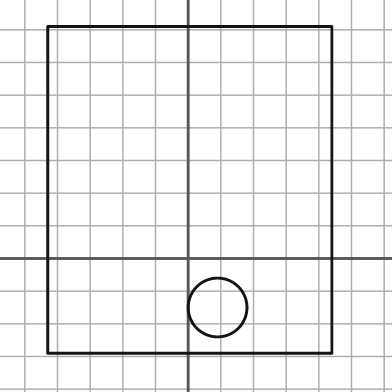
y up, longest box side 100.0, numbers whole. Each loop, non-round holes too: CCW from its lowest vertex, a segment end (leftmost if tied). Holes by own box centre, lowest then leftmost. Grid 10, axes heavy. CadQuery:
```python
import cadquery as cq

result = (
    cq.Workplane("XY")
    .moveTo(-43.0, -29.0)
    .lineTo(44.0, -29.0)
    .lineTo(44.0, 71.0)
    .lineTo(-43.0, 71.0)
    .close()
    .moveTo(9.0, -15.0)
    .circle(9.0)
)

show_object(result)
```